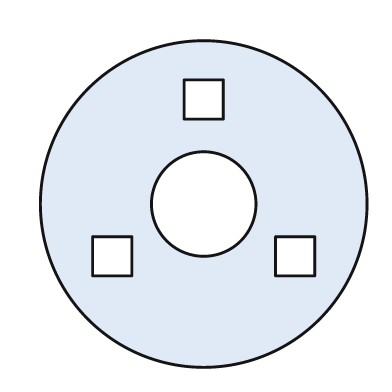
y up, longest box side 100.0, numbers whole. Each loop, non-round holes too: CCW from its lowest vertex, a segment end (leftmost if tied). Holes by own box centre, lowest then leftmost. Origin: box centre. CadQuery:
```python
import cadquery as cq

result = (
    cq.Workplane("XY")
    .moveTo(0.0, 0.0)
    .circle(50.0)
    .moveTo(-34.0, -22.0)
    .lineTo(-22.0, -22.0)
    .lineTo(-22.0, -10.0)
    .lineTo(-34.0, -10.0)
    .close()
    .moveTo(22.0, -22.0)
    .lineTo(34.0, -22.0)
    .lineTo(34.0, -10.0)
    .lineTo(22.0, -10.0)
    .close()
    .moveTo(0.0, 0.0)
    .circle(16.0)
    .moveTo(-6.0, 26.0)
    .lineTo(6.0, 26.0)
    .lineTo(6.0, 38.0)
    .lineTo(-6.0, 38.0)
    .close()
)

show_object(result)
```